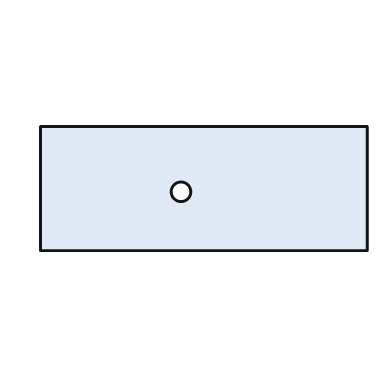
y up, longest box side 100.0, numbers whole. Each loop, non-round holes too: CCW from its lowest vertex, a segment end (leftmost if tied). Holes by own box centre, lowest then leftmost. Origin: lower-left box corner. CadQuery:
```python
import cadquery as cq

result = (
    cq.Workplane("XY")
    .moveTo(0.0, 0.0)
    .lineTo(100.0, 0.0)
    .lineTo(100.0, 38.0)
    .lineTo(0.0, 38.0)
    .close()
    .moveTo(43.0, 18.0)
    .circle(3.0)
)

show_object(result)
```